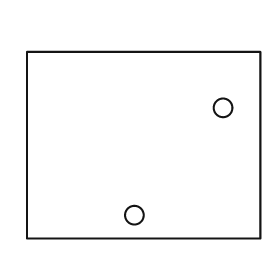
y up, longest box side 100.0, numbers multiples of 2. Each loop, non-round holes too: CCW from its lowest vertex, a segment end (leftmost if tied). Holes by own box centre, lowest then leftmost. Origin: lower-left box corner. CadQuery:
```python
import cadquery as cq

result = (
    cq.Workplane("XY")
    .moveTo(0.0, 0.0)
    .lineTo(100.0, 0.0)
    .lineTo(100.0, 80.0)
    .lineTo(0.0, 80.0)
    .close()
    .moveTo(46.0, 10.0)
    .circle(4.0)
    .moveTo(84.0, 56.0)
    .circle(4.0)
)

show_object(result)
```